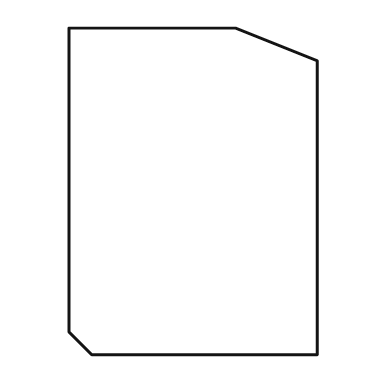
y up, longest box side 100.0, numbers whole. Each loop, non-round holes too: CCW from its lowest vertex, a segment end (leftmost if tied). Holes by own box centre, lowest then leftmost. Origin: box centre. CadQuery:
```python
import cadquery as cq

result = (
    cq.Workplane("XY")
    .moveTo(-31.0, -50.0)
    .lineTo(38.0, -50.0)
    .lineTo(38.0, 40.0)
    .lineTo(13.0, 50.0)
    .lineTo(-38.0, 50.0)
    .lineTo(-38.0, -43.0)
    .close()
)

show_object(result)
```